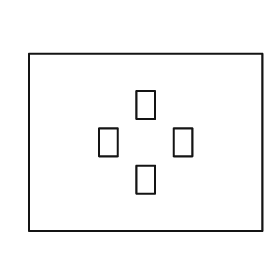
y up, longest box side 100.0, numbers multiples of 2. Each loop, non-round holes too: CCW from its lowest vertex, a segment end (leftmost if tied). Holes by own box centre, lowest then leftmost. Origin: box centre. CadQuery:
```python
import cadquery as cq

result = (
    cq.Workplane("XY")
    .moveTo(-50.0, -38.0)
    .lineTo(50.0, -38.0)
    .lineTo(50.0, 38.0)
    .lineTo(-50.0, 38.0)
    .close()
    .moveTo(-4.0, -22.0)
    .lineTo(4.0, -22.0)
    .lineTo(4.0, -10.0)
    .lineTo(-4.0, -10.0)
    .close()
    .moveTo(-20.0, -6.0)
    .lineTo(-12.0, -6.0)
    .lineTo(-12.0, 6.0)
    .lineTo(-20.0, 6.0)
    .close()
    .moveTo(12.0, -6.0)
    .lineTo(20.0, -6.0)
    .lineTo(20.0, 6.0)
    .lineTo(12.0, 6.0)
    .close()
    .moveTo(-4.0, 10.0)
    .lineTo(4.0, 10.0)
    .lineTo(4.0, 22.0)
    .lineTo(-4.0, 22.0)
    .close()
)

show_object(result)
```